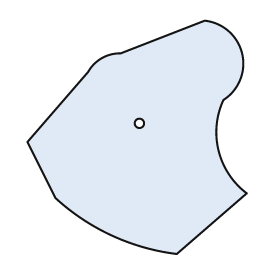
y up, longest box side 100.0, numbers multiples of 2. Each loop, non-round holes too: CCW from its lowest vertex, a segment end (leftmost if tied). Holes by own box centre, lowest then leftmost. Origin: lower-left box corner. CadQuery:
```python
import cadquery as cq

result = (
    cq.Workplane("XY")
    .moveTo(64.0, 0.0)
    .lineTo(94.0, 26.0)
    .threePointArc((82.0, 44.0), (84.0, 66.0))
    .threePointArc((92.0, 86.0), (76.0, 100.0))
    .lineTo(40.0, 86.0)
    .threePointArc((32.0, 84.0), (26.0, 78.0))
    .lineTo(0.0, 48.0)
    .lineTo(12.0, 24.0)
    .threePointArc((36.0, 8.0), (64.0, 0.0))
    .close()
    .moveTo(48.0, 56.0)
    .circle(2.0)
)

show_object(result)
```